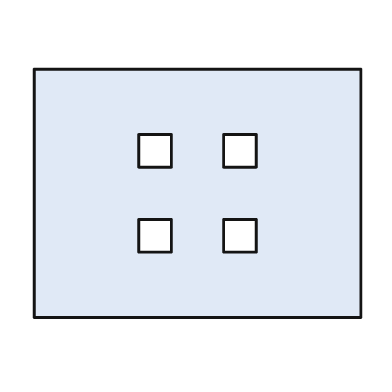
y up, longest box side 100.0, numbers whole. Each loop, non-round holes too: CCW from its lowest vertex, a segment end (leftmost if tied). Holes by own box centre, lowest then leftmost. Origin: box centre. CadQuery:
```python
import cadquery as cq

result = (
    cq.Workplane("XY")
    .moveTo(-50.0, -38.0)
    .lineTo(50.0, -38.0)
    .lineTo(50.0, 38.0)
    .lineTo(-50.0, 38.0)
    .close()
    .moveTo(-18.0, -18.0)
    .lineTo(-8.0, -18.0)
    .lineTo(-8.0, -8.0)
    .lineTo(-18.0, -8.0)
    .close()
    .moveTo(8.0, -18.0)
    .lineTo(18.0, -18.0)
    .lineTo(18.0, -8.0)
    .lineTo(8.0, -8.0)
    .close()
    .moveTo(-18.0, 8.0)
    .lineTo(-8.0, 8.0)
    .lineTo(-8.0, 18.0)
    .lineTo(-18.0, 18.0)
    .close()
    .moveTo(8.0, 8.0)
    .lineTo(18.0, 8.0)
    .lineTo(18.0, 18.0)
    .lineTo(8.0, 18.0)
    .close()
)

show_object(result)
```